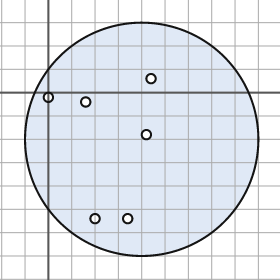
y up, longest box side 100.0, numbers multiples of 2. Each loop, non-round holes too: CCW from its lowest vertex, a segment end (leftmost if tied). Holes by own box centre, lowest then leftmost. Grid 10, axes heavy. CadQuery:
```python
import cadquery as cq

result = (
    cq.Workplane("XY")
    .moveTo(40.0, -20.0)
    .circle(50.0)
    .moveTo(20.0, -54.0)
    .circle(2.0)
    .moveTo(34.0, -54.0)
    .circle(2.0)
    .moveTo(42.0, -18.0)
    .circle(2.0)
    .moveTo(16.0, -4.0)
    .circle(2.0)
    .moveTo(0.0, -2.0)
    .circle(2.0)
    .moveTo(44.0, 6.0)
    .circle(2.0)
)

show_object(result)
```